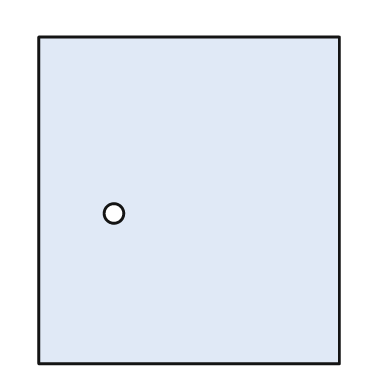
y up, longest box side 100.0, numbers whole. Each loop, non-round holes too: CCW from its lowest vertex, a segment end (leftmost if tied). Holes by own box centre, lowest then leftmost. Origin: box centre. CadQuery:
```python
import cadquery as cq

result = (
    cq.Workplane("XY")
    .moveTo(-46.0, -50.0)
    .lineTo(46.0, -50.0)
    .lineTo(46.0, 50.0)
    .lineTo(-46.0, 50.0)
    .close()
    .moveTo(-23.0, -4.0)
    .circle(3.0)
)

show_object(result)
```